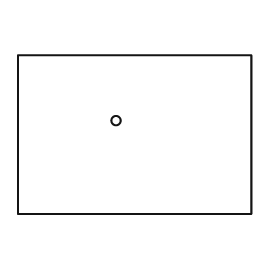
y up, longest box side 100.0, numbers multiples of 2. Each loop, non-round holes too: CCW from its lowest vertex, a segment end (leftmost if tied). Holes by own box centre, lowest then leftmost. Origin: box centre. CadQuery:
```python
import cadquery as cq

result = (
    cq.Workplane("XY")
    .moveTo(-50.0, -34.0)
    .lineTo(50.0, -34.0)
    .lineTo(50.0, 34.0)
    .lineTo(-50.0, 34.0)
    .close()
    .moveTo(-8.0, 6.0)
    .circle(2.0)
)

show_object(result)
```